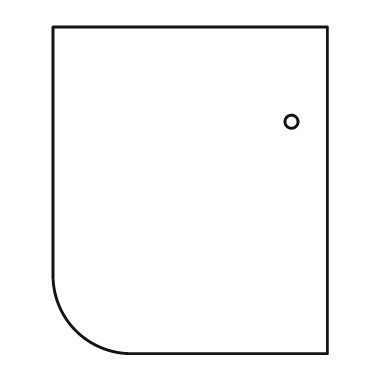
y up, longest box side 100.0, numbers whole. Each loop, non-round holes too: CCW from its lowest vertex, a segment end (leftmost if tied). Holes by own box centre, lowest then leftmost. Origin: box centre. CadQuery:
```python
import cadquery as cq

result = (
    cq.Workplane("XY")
    .moveTo(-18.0, -50.0)
    .lineTo(42.0, -50.0)
    .lineTo(42.0, 50.0)
    .lineTo(-42.0, 50.0)
    .lineTo(-42.0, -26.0)
    .threePointArc((-35.0, -43.0), (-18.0, -50.0))
    .close()
    .moveTo(31.0, 21.0)
    .circle(2.0)
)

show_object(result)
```